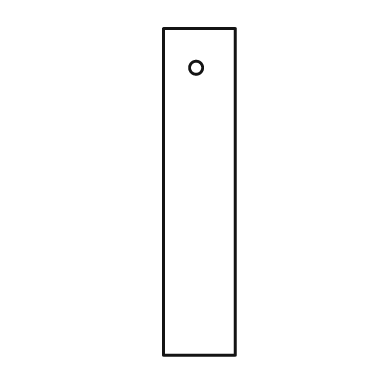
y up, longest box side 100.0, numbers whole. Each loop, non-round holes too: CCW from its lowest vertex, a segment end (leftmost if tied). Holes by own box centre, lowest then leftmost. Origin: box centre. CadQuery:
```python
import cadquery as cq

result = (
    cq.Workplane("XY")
    .moveTo(-11.0, -50.0)
    .lineTo(11.0, -50.0)
    .lineTo(11.0, 50.0)
    .lineTo(-11.0, 50.0)
    .close()
    .moveTo(-1.0, 38.0)
    .circle(2.0)
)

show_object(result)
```